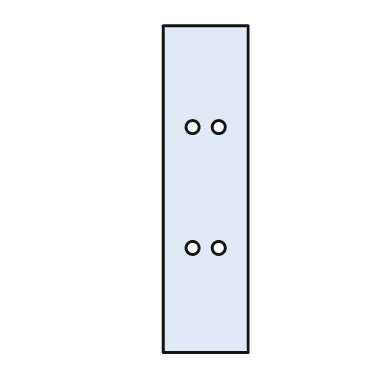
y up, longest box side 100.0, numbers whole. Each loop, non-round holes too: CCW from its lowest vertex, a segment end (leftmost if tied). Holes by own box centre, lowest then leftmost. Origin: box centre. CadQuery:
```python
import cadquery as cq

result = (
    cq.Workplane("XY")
    .moveTo(-13.0, -50.0)
    .lineTo(13.0, -50.0)
    .lineTo(13.0, 50.0)
    .lineTo(-13.0, 50.0)
    .close()
    .moveTo(-4.0, -18.0)
    .circle(2.0)
    .moveTo(4.0, -18.0)
    .circle(2.0)
    .moveTo(-4.0, 19.0)
    .circle(2.0)
    .moveTo(4.0, 19.0)
    .circle(2.0)
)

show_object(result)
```